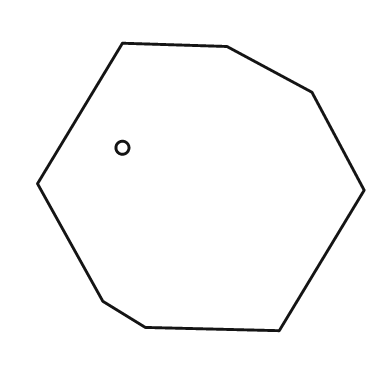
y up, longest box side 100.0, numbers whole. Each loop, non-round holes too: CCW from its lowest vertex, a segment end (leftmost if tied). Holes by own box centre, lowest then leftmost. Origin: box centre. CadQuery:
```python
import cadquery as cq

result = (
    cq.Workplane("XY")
    .moveTo(24.0, -44.0)
    .lineTo(50.0, -1.0)
    .lineTo(34.0, 29.0)
    .lineTo(8.0, 43.0)
    .lineTo(-24.0, 44.0)
    .lineTo(-50.0, 1.0)
    .lineTo(-30.0, -35.0)
    .lineTo(-17.0, -43.0)
    .close()
    .moveTo(-24.0, 12.0)
    .circle(2.0)
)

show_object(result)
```